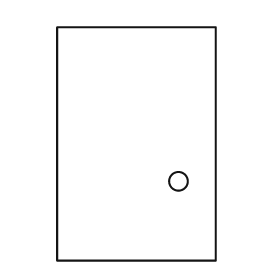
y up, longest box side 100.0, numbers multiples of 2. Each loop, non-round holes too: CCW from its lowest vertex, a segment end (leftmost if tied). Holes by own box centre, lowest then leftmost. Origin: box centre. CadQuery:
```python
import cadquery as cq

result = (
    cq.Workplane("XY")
    .moveTo(-34.0, -50.0)
    .lineTo(34.0, -50.0)
    .lineTo(34.0, 50.0)
    .lineTo(-34.0, 50.0)
    .close()
    .moveTo(18.0, -16.0)
    .circle(4.0)
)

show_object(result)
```